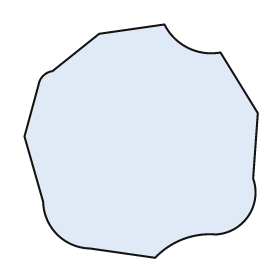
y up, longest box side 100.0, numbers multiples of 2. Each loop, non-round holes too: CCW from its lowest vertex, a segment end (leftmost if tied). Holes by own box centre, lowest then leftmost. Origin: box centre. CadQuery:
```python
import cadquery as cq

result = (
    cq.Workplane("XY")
    .moveTo(6.0, -50.0)
    .threePointArc((18.0, -42.0), (32.0, -40.0))
    .threePointArc((46.0, -32.0), (48.0, -16.0))
    .lineTo(50.0, 12.0)
    .lineTo(34.0, 38.0)
    .threePointArc((20.0, 40.0), (10.0, 50.0))
    .lineTo(-18.0, 46.0)
    .lineTo(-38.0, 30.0)
    .threePointArc((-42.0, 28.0), (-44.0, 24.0))
    .lineTo(-50.0, 2.0)
    .lineTo(-42.0, -26.0)
    .threePointArc((-36.0, -40.0), (-22.0, -46.0))
    .close()
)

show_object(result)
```